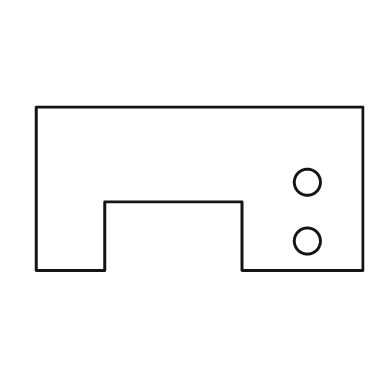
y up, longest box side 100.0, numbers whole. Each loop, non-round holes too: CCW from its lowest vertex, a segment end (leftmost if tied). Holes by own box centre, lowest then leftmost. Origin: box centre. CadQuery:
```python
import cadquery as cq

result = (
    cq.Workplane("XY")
    .moveTo(-50.0, -25.0)
    .lineTo(-29.0, -25.0)
    .lineTo(-29.0, -4.0)
    .lineTo(13.0, -4.0)
    .lineTo(13.0, -25.0)
    .lineTo(50.0, -25.0)
    .lineTo(50.0, 25.0)
    .lineTo(-50.0, 25.0)
    .close()
    .moveTo(33.0, -16.0)
    .circle(4.0)
    .moveTo(33.0, 2.0)
    .circle(4.0)
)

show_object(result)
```